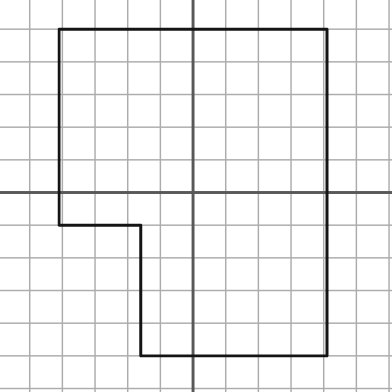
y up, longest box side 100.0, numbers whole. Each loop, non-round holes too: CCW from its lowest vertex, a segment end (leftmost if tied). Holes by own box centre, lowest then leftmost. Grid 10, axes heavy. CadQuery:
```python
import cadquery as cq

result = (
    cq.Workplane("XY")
    .moveTo(-16.0, -50.0)
    .lineTo(41.0, -50.0)
    .lineTo(41.0, 50.0)
    .lineTo(-41.0, 50.0)
    .lineTo(-41.0, -10.0)
    .lineTo(-16.0, -10.0)
    .close()
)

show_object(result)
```